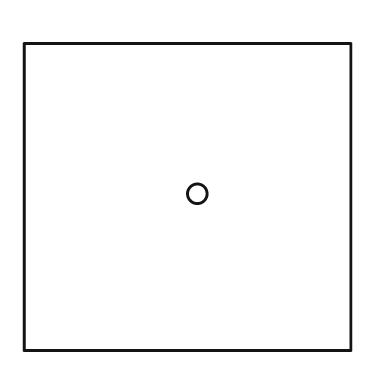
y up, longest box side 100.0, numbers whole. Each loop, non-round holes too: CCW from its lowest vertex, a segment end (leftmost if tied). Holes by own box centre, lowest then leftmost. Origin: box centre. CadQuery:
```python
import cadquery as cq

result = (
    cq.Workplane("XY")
    .moveTo(-50.0, -47.0)
    .lineTo(50.0, -47.0)
    .lineTo(50.0, 47.0)
    .lineTo(-50.0, 47.0)
    .close()
    .moveTo(3.0, 1.0)
    .circle(3.0)
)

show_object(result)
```